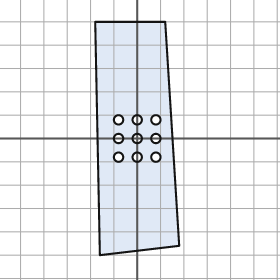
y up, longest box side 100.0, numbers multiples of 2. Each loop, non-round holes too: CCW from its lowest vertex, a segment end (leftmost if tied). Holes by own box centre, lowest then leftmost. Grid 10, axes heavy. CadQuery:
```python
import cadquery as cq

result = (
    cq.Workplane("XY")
    .moveTo(-16.0, -50.0)
    .lineTo(18.0, -46.0)
    .lineTo(12.0, 50.0)
    .lineTo(-18.0, 50.0)
    .close()
    .moveTo(-8.0, -8.0)
    .circle(2.0)
    .moveTo(0.0, -8.0)
    .circle(2.0)
    .moveTo(8.0, -8.0)
    .circle(2.0)
    .moveTo(-8.0, 0.0)
    .circle(2.0)
    .moveTo(0.0, 0.0)
    .circle(2.0)
    .moveTo(8.0, 0.0)
    .circle(2.0)
    .moveTo(-8.0, 8.0)
    .circle(2.0)
    .moveTo(0.0, 8.0)
    .circle(2.0)
    .moveTo(8.0, 8.0)
    .circle(2.0)
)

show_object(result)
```